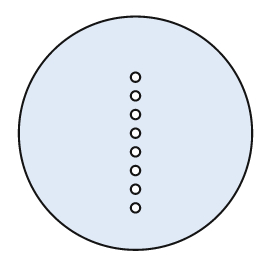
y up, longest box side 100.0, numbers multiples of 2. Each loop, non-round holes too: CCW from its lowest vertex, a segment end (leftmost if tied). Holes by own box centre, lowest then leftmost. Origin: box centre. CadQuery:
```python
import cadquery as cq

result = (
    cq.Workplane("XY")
    .moveTo(0.0, 0.0)
    .circle(50.0)
    .moveTo(0.0, -32.0)
    .circle(2.0)
    .moveTo(0.0, -24.0)
    .circle(2.0)
    .moveTo(0.0, -16.0)
    .circle(2.0)
    .moveTo(0.0, -8.0)
    .circle(2.0)
    .moveTo(0.0, 0.0)
    .circle(2.0)
    .moveTo(0.0, 8.0)
    .circle(2.0)
    .moveTo(0.0, 16.0)
    .circle(2.0)
    .moveTo(0.0, 24.0)
    .circle(2.0)
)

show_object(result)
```